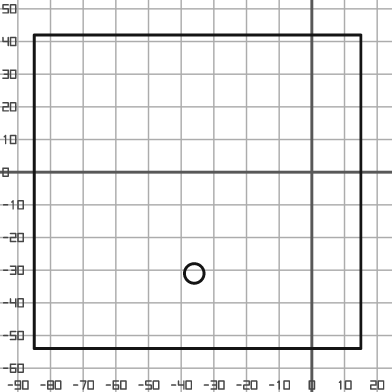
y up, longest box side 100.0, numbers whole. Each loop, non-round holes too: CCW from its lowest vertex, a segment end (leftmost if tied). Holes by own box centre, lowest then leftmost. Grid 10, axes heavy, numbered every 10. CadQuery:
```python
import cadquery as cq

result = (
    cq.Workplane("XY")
    .moveTo(-85.0, -54.0)
    .lineTo(15.0, -54.0)
    .lineTo(15.0, 42.0)
    .lineTo(-85.0, 42.0)
    .close()
    .moveTo(-36.0, -31.0)
    .circle(3.0)
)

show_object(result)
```